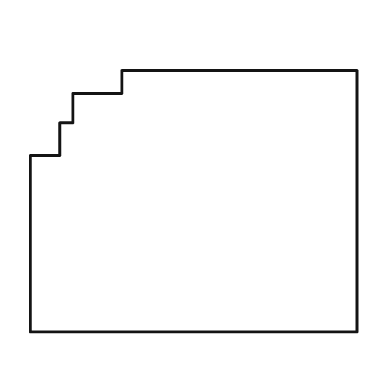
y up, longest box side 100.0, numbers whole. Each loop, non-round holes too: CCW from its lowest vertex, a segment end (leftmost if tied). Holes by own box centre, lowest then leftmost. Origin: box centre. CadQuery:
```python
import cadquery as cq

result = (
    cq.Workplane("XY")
    .moveTo(-50.0, -40.0)
    .lineTo(50.0, -40.0)
    .lineTo(50.0, 40.0)
    .lineTo(-22.0, 40.0)
    .lineTo(-22.0, 33.0)
    .lineTo(-37.0, 33.0)
    .lineTo(-37.0, 24.0)
    .lineTo(-41.0, 24.0)
    .lineTo(-41.0, 14.0)
    .lineTo(-50.0, 14.0)
    .close()
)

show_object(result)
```